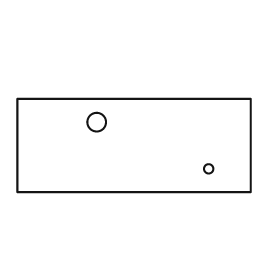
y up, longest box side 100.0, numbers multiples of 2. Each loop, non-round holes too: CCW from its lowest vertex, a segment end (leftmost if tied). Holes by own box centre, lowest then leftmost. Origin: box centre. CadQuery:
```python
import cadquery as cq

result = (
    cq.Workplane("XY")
    .moveTo(-50.0, -20.0)
    .lineTo(50.0, -20.0)
    .lineTo(50.0, 20.0)
    .lineTo(-50.0, 20.0)
    .close()
    .moveTo(32.0, -10.0)
    .circle(2.0)
    .moveTo(-16.0, 10.0)
    .circle(4.0)
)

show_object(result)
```